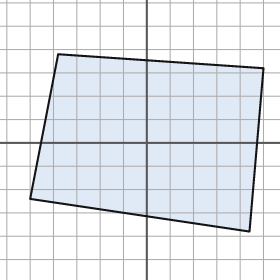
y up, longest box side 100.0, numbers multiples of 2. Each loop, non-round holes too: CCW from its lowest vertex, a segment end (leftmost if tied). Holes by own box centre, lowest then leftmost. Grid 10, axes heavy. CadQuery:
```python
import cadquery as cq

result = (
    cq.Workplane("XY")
    .moveTo(44.0, -38.0)
    .lineTo(50.0, 32.0)
    .lineTo(-38.0, 38.0)
    .lineTo(-50.0, -24.0)
    .close()
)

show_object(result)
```